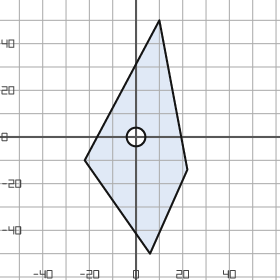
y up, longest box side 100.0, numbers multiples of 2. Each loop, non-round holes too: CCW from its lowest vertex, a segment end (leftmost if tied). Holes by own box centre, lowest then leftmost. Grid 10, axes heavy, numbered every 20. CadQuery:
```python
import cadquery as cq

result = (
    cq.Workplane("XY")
    .moveTo(6.0, -50.0)
    .lineTo(22.0, -14.0)
    .lineTo(10.0, 50.0)
    .lineTo(-22.0, -10.0)
    .close()
    .moveTo(0.0, 0.0)
    .circle(4.0)
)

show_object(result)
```